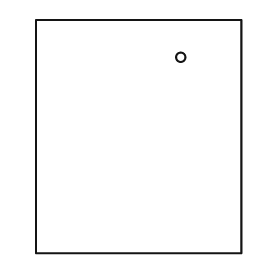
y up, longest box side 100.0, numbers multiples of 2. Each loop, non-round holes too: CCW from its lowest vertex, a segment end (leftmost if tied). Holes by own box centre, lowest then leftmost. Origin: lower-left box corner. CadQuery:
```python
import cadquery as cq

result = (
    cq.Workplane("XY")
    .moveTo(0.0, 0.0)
    .lineTo(88.0, 0.0)
    .lineTo(88.0, 100.0)
    .lineTo(0.0, 100.0)
    .close()
    .moveTo(62.0, 84.0)
    .circle(2.0)
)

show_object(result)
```